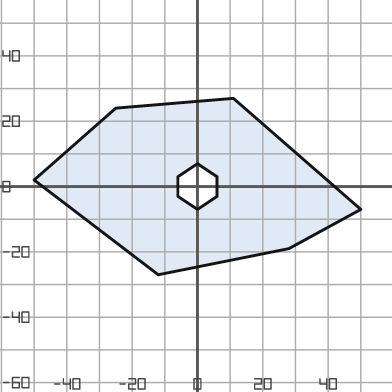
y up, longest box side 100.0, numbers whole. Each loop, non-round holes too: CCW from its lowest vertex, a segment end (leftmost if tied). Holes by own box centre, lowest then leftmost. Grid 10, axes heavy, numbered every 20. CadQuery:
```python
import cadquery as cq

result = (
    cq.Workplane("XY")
    .moveTo(-12.0, -27.0)
    .lineTo(28.0, -19.0)
    .lineTo(50.0, -7.0)
    .lineTo(11.0, 27.0)
    .lineTo(-25.0, 24.0)
    .lineTo(-50.0, 2.0)
    .close()
    .moveTo(0.0, -7.0)
    .lineTo(6.0, -3.0)
    .lineTo(6.0, 3.0)
    .lineTo(0.0, 7.0)
    .lineTo(-6.0, 3.0)
    .lineTo(-6.0, -3.0)
    .close()
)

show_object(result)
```